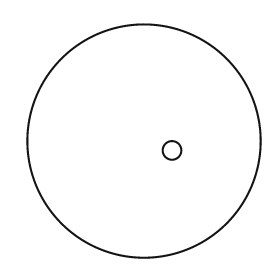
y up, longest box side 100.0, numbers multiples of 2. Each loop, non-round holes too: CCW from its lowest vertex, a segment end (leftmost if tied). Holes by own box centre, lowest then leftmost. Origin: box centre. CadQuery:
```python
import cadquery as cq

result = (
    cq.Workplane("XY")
    .moveTo(0.0, 0.0)
    .circle(50.0)
    .moveTo(12.0, -4.0)
    .circle(4.0)
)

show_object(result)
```